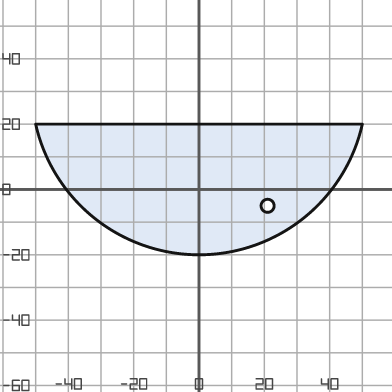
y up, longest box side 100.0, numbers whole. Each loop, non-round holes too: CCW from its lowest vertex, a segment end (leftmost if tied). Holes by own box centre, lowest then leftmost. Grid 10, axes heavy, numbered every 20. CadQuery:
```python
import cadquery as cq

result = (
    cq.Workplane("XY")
    .moveTo(-50.0, 20.0)
    .threePointArc((0.0, -20.0), (50.0, 20.0))
    .close()
    .moveTo(21.0, -5.0)
    .circle(2.0)
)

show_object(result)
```